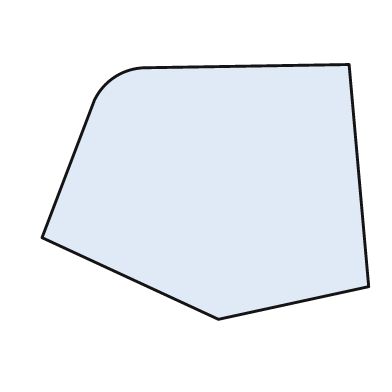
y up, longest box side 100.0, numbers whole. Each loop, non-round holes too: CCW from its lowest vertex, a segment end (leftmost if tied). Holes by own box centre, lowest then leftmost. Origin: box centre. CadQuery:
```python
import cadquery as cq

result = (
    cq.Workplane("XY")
    .moveTo(4.0, -39.0)
    .lineTo(50.0, -29.0)
    .lineTo(44.0, 39.0)
    .lineTo(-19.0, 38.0)
    .threePointArc((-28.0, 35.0), (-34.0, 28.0))
    .lineTo(-50.0, -14.0)
    .close()
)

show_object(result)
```